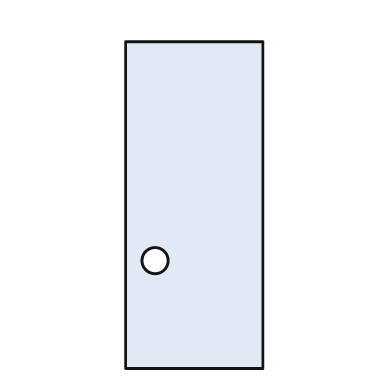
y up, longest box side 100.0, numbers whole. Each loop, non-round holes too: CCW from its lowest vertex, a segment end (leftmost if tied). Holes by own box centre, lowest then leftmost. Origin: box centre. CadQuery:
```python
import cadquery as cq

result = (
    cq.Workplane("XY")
    .moveTo(-21.0, -50.0)
    .lineTo(21.0, -50.0)
    .lineTo(21.0, 50.0)
    .lineTo(-21.0, 50.0)
    .close()
    .moveTo(-12.0, -17.0)
    .circle(4.0)
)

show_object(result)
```